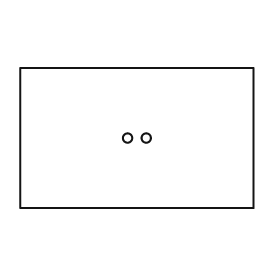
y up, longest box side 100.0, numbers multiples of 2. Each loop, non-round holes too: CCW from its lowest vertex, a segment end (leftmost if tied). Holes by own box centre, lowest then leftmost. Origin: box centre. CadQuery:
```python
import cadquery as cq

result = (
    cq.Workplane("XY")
    .moveTo(-50.0, -30.0)
    .lineTo(50.0, -30.0)
    .lineTo(50.0, 30.0)
    .lineTo(-50.0, 30.0)
    .close()
    .moveTo(-4.0, 0.0)
    .circle(2.0)
    .moveTo(4.0, 0.0)
    .circle(2.0)
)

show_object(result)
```